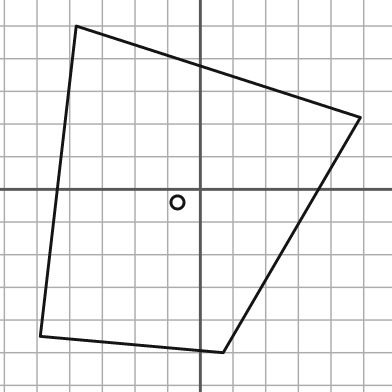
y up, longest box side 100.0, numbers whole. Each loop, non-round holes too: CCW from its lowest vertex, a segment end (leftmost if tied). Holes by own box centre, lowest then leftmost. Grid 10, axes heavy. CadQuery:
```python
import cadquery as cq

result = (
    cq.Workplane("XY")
    .moveTo(7.0, -50.0)
    .lineTo(49.0, 22.0)
    .lineTo(-38.0, 50.0)
    .lineTo(-49.0, -45.0)
    .close()
    .moveTo(-7.0, -4.0)
    .circle(2.0)
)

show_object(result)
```